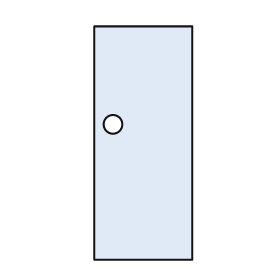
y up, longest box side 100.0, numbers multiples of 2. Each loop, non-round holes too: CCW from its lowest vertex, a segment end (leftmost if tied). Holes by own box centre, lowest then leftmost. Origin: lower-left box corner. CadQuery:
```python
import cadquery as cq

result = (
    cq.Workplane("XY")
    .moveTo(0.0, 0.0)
    .lineTo(42.0, 0.0)
    .lineTo(42.0, 100.0)
    .lineTo(0.0, 100.0)
    .close()
    .moveTo(8.0, 58.0)
    .circle(4.0)
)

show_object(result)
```